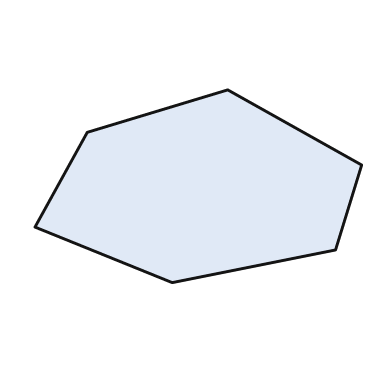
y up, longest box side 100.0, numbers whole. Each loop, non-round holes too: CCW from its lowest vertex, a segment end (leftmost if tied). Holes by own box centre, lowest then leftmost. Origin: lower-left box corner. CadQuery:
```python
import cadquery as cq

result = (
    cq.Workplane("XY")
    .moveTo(42.0, 0.0)
    .lineTo(92.0, 10.0)
    .lineTo(100.0, 36.0)
    .lineTo(59.0, 59.0)
    .lineTo(16.0, 46.0)
    .lineTo(0.0, 17.0)
    .close()
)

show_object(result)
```